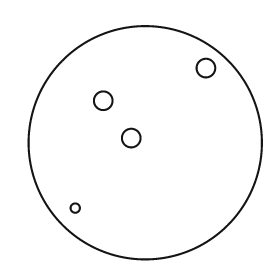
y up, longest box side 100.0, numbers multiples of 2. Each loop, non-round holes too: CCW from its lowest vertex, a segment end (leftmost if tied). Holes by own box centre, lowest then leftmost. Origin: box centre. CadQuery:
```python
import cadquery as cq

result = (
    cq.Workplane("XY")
    .moveTo(0.0, 0.0)
    .circle(50.0)
    .moveTo(-30.0, -28.0)
    .circle(2.0)
    .moveTo(-6.0, 2.0)
    .circle(4.0)
    .moveTo(-18.0, 18.0)
    .circle(4.0)
    .moveTo(26.0, 32.0)
    .circle(4.0)
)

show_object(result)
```